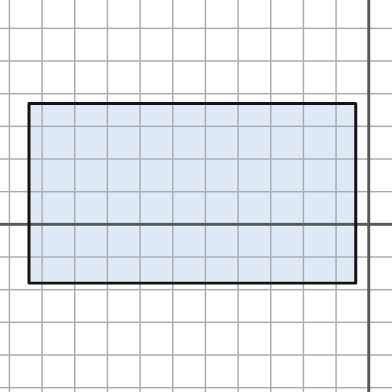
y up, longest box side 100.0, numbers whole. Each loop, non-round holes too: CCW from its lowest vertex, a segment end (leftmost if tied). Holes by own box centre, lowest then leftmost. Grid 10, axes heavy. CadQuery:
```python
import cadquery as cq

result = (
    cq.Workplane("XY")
    .moveTo(-104.0, -18.0)
    .lineTo(-4.0, -18.0)
    .lineTo(-4.0, 37.0)
    .lineTo(-104.0, 37.0)
    .close()
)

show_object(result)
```